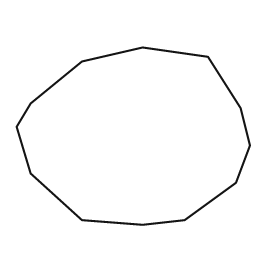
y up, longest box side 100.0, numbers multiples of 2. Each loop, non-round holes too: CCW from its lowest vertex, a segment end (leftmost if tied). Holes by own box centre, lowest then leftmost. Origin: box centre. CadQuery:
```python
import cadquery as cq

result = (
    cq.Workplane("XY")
    .moveTo(4.0, -38.0)
    .lineTo(22.0, -36.0)
    .lineTo(44.0, -20.0)
    .lineTo(50.0, -4.0)
    .lineTo(46.0, 12.0)
    .lineTo(32.0, 34.0)
    .lineTo(4.0, 38.0)
    .lineTo(-22.0, 32.0)
    .lineTo(-44.0, 14.0)
    .lineTo(-50.0, 4.0)
    .lineTo(-44.0, -16.0)
    .lineTo(-22.0, -36.0)
    .close()
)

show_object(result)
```